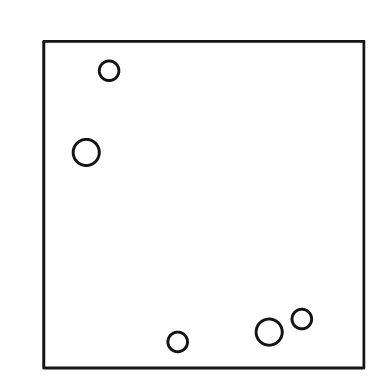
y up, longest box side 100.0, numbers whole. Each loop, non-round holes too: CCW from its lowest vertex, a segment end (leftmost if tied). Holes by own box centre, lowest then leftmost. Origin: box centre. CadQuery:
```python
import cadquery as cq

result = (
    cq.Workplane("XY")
    .moveTo(-49.0, -50.0)
    .lineTo(49.0, -50.0)
    .lineTo(49.0, 50.0)
    .lineTo(-49.0, 50.0)
    .close()
    .moveTo(-8.0, -42.0)
    .circle(3.0)
    .moveTo(20.0, -39.0)
    .circle(4.0)
    .moveTo(30.0, -35.0)
    .circle(3.0)
    .moveTo(-36.0, 16.0)
    .circle(4.0)
    .moveTo(-29.0, 41.0)
    .circle(3.0)
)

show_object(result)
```